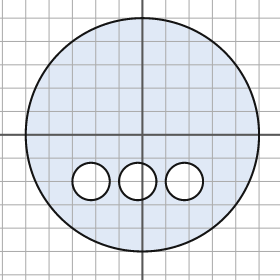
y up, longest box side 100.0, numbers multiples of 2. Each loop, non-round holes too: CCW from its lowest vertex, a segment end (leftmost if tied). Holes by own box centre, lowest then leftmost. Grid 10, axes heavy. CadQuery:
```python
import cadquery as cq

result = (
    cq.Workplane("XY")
    .moveTo(0.0, 0.0)
    .circle(50.0)
    .moveTo(-22.0, -20.0)
    .circle(8.0)
    .moveTo(-2.0, -20.0)
    .circle(8.0)
    .moveTo(18.0, -20.0)
    .circle(8.0)
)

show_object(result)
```